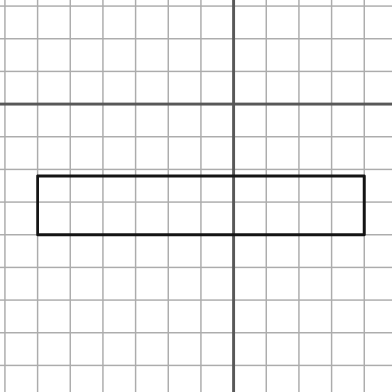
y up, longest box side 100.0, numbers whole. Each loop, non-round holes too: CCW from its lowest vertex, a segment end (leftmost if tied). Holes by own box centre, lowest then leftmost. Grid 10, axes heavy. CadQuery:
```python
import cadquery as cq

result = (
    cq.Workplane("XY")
    .moveTo(-60.0, -40.0)
    .lineTo(40.0, -40.0)
    .lineTo(40.0, -22.0)
    .lineTo(-60.0, -22.0)
    .close()
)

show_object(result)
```